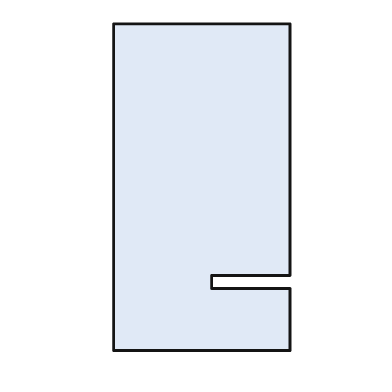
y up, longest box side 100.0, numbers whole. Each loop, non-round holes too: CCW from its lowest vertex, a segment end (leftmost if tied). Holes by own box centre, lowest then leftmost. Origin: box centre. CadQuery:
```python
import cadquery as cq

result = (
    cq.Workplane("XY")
    .moveTo(-27.0, -50.0)
    .lineTo(27.0, -50.0)
    .lineTo(27.0, -31.0)
    .lineTo(3.0, -31.0)
    .lineTo(3.0, -27.0)
    .lineTo(27.0, -27.0)
    .lineTo(27.0, 50.0)
    .lineTo(-27.0, 50.0)
    .close()
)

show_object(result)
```